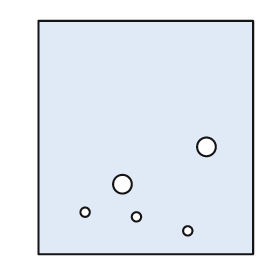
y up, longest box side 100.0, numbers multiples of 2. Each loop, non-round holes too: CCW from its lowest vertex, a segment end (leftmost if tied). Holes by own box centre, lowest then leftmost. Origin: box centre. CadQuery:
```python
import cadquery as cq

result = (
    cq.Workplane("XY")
    .moveTo(-46.0, -50.0)
    .lineTo(46.0, -50.0)
    .lineTo(46.0, 50.0)
    .lineTo(-46.0, 50.0)
    .close()
    .moveTo(18.0, -40.0)
    .circle(2.0)
    .moveTo(-4.0, -34.0)
    .circle(2.0)
    .moveTo(-26.0, -32.0)
    .circle(2.0)
    .moveTo(-10.0, -20.0)
    .circle(4.0)
    .moveTo(26.0, -4.0)
    .circle(4.0)
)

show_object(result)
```